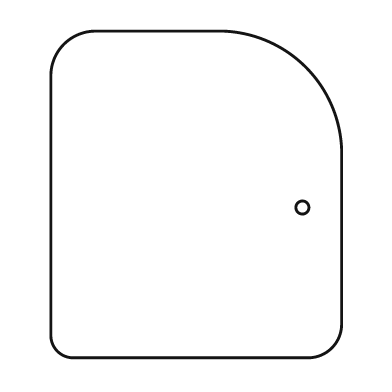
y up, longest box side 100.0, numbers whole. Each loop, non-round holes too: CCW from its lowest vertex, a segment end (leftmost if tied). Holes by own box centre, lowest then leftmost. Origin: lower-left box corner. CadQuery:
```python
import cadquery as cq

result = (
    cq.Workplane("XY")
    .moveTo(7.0, 0.0)
    .lineTo(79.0, 0.0)
    .threePointArc((86.0, 3.0), (89.0, 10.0))
    .lineTo(89.0, 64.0)
    .threePointArc((78.0, 89.0), (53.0, 100.0))
    .lineTo(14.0, 100.0)
    .threePointArc((4.0, 96.0), (0.0, 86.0))
    .lineTo(0.0, 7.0)
    .threePointArc((2.0, 2.0), (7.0, 0.0))
    .close()
    .moveTo(77.0, 46.0)
    .circle(2.0)
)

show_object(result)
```